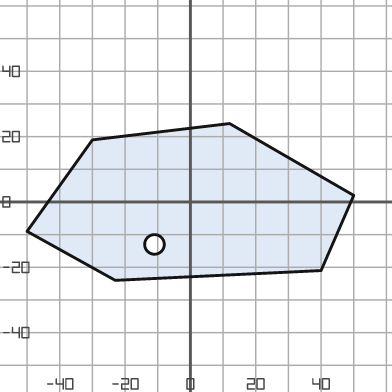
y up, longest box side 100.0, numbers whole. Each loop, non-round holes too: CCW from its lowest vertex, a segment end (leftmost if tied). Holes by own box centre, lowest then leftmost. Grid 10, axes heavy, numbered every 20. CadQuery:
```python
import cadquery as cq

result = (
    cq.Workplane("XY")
    .moveTo(-23.0, -24.0)
    .lineTo(40.0, -21.0)
    .lineTo(50.0, 2.0)
    .lineTo(12.0, 24.0)
    .lineTo(-30.0, 19.0)
    .lineTo(-50.0, -9.0)
    .close()
    .moveTo(-11.0, -13.0)
    .circle(3.0)
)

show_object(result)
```